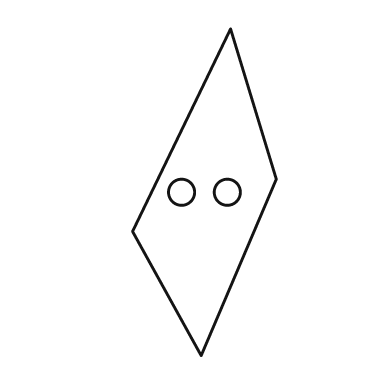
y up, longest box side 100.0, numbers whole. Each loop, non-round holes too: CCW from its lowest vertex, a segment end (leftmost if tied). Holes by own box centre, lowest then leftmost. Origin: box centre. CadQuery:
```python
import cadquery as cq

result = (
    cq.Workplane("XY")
    .moveTo(-1.0, -50.0)
    .lineTo(22.0, 4.0)
    .lineTo(8.0, 50.0)
    .lineTo(-22.0, -12.0)
    .close()
    .moveTo(-7.0, 0.0)
    .circle(4.0)
    .moveTo(7.0, 0.0)
    .circle(4.0)
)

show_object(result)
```